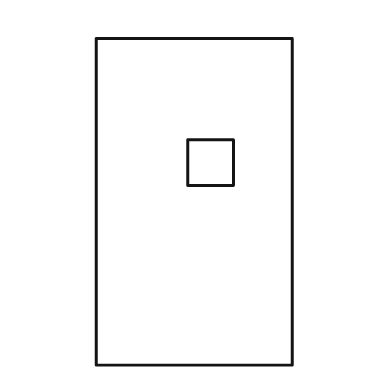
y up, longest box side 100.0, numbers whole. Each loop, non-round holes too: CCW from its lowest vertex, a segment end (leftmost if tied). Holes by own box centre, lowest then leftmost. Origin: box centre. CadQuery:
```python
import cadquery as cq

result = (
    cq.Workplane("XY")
    .moveTo(-30.0, -50.0)
    .lineTo(30.0, -50.0)
    .lineTo(30.0, 50.0)
    .lineTo(-30.0, 50.0)
    .close()
    .moveTo(-2.0, 5.0)
    .lineTo(12.0, 5.0)
    .lineTo(12.0, 19.0)
    .lineTo(-2.0, 19.0)
    .close()
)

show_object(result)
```